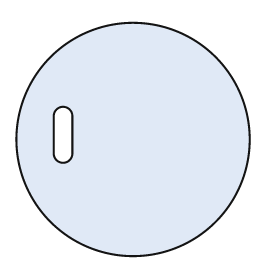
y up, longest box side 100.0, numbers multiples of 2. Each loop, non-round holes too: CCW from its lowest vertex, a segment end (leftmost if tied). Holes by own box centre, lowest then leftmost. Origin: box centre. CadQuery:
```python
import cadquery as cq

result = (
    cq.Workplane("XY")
    .moveTo(0.0, 0.0)
    .circle(50.0)
    .moveTo(-34.0, -6.0)
    .threePointArc((-30.0, -10.0), (-26.0, -6.0))
    .lineTo(-26.0, 10.0)
    .threePointArc((-30.0, 14.0), (-34.0, 10.0))
    .close()
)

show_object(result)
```